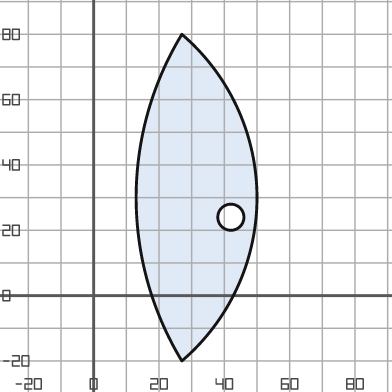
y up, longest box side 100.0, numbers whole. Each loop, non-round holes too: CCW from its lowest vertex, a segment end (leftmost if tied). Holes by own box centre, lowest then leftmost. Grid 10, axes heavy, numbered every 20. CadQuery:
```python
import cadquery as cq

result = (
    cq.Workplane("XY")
    .moveTo(27.0, -20.0)
    .threePointArc((50.0, 30.0), (27.0, 80.0))
    .threePointArc((13.0, 30.0), (27.0, -20.0))
    .close()
    .moveTo(42.0, 24.0)
    .circle(4.0)
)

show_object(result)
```